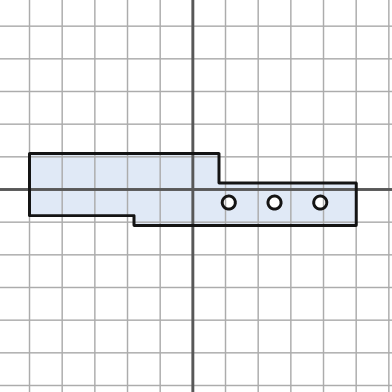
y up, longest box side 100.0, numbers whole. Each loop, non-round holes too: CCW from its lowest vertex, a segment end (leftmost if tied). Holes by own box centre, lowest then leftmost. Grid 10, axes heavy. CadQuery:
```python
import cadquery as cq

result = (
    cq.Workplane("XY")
    .moveTo(-18.0, -11.0)
    .lineTo(50.0, -11.0)
    .lineTo(50.0, 2.0)
    .lineTo(8.0, 2.0)
    .lineTo(8.0, 11.0)
    .lineTo(-50.0, 11.0)
    .lineTo(-50.0, -8.0)
    .lineTo(-18.0, -8.0)
    .close()
    .moveTo(11.0, -4.0)
    .circle(2.0)
    .moveTo(25.0, -4.0)
    .circle(2.0)
    .moveTo(39.0, -4.0)
    .circle(2.0)
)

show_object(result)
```